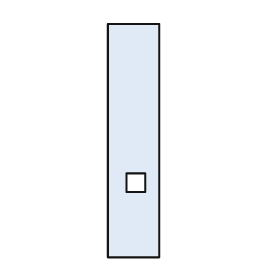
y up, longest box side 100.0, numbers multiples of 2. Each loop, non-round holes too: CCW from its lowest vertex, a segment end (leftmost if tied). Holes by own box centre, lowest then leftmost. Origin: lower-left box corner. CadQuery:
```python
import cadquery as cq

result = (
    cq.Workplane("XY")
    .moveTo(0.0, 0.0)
    .lineTo(22.0, 0.0)
    .lineTo(22.0, 100.0)
    .lineTo(0.0, 100.0)
    .close()
    .moveTo(8.0, 28.0)
    .lineTo(16.0, 28.0)
    .lineTo(16.0, 36.0)
    .lineTo(8.0, 36.0)
    .close()
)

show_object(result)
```